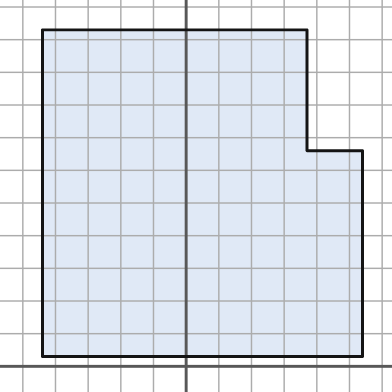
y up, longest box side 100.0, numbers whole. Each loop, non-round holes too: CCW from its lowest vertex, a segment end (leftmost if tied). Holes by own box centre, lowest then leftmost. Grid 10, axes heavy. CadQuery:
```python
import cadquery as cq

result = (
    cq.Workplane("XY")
    .moveTo(-44.0, 3.0)
    .lineTo(54.0, 3.0)
    .lineTo(54.0, 66.0)
    .lineTo(37.0, 66.0)
    .lineTo(37.0, 103.0)
    .lineTo(-44.0, 103.0)
    .close()
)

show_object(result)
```